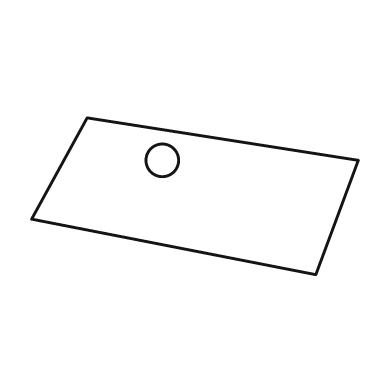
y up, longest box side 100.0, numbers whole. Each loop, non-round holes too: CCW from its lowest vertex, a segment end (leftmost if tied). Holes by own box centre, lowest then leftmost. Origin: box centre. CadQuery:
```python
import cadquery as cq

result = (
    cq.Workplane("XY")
    .moveTo(37.0, -24.0)
    .lineTo(50.0, 11.0)
    .lineTo(-33.0, 24.0)
    .lineTo(-50.0, -7.0)
    .close()
    .moveTo(-10.0, 11.0)
    .circle(5.0)
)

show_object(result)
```